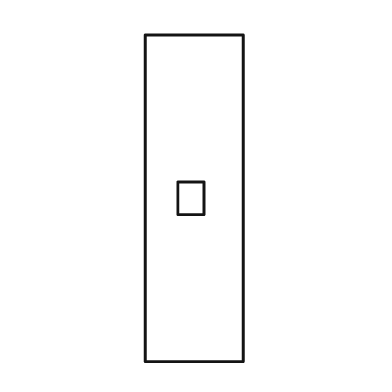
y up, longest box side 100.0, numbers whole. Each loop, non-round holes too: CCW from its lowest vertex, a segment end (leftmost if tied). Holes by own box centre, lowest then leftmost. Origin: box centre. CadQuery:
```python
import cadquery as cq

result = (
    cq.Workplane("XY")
    .moveTo(-15.0, -50.0)
    .lineTo(15.0, -50.0)
    .lineTo(15.0, 50.0)
    .lineTo(-15.0, 50.0)
    .close()
    .moveTo(-5.0, -5.0)
    .lineTo(3.0, -5.0)
    .lineTo(3.0, 5.0)
    .lineTo(-5.0, 5.0)
    .close()
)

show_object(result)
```